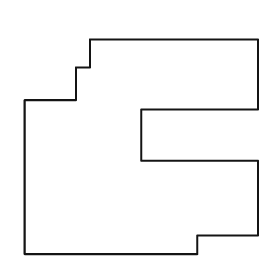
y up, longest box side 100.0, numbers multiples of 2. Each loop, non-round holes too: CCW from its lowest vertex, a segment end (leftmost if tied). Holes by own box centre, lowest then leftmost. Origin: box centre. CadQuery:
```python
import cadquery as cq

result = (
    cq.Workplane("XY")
    .moveTo(-50.0, -46.0)
    .lineTo(24.0, -46.0)
    .lineTo(24.0, -38.0)
    .lineTo(50.0, -38.0)
    .lineTo(50.0, -6.0)
    .lineTo(0.0, -6.0)
    .lineTo(0.0, 16.0)
    .lineTo(50.0, 16.0)
    .lineTo(50.0, 46.0)
    .lineTo(-22.0, 46.0)
    .lineTo(-22.0, 34.0)
    .lineTo(-28.0, 34.0)
    .lineTo(-28.0, 20.0)
    .lineTo(-50.0, 20.0)
    .close()
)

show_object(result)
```